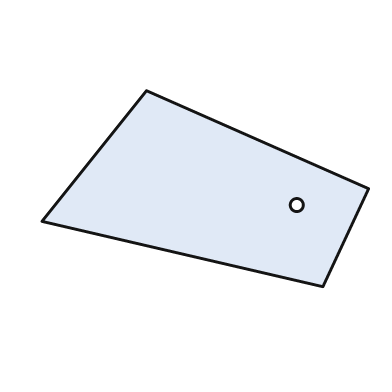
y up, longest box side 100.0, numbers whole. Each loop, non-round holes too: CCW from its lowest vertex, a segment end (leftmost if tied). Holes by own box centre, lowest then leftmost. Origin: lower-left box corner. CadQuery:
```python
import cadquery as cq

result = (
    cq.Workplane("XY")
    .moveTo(86.0, 0.0)
    .lineTo(100.0, 30.0)
    .lineTo(32.0, 60.0)
    .lineTo(0.0, 20.0)
    .close()
    .moveTo(78.0, 25.0)
    .circle(2.0)
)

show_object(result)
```